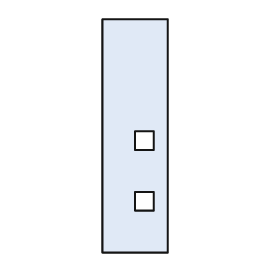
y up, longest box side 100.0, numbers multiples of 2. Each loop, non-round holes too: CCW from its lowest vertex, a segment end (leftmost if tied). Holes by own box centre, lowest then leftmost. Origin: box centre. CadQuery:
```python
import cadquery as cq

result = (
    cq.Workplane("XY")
    .moveTo(-14.0, -50.0)
    .lineTo(14.0, -50.0)
    .lineTo(14.0, 50.0)
    .lineTo(-14.0, 50.0)
    .close()
    .moveTo(0.0, -32.0)
    .lineTo(8.0, -32.0)
    .lineTo(8.0, -24.0)
    .lineTo(0.0, -24.0)
    .close()
    .moveTo(0.0, -6.0)
    .lineTo(8.0, -6.0)
    .lineTo(8.0, 2.0)
    .lineTo(0.0, 2.0)
    .close()
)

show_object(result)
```